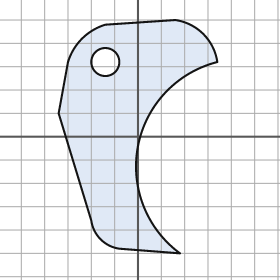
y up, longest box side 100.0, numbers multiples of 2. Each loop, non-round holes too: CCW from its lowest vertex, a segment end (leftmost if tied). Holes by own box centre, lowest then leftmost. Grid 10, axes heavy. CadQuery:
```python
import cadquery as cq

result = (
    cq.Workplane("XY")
    .moveTo(18.0, -50.0)
    .threePointArc((0.0, -4.0), (34.0, 32.0))
    .threePointArc((28.0, 44.0), (16.0, 50.0))
    .lineTo(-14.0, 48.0)
    .threePointArc((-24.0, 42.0), (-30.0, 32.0))
    .lineTo(-34.0, 10.0)
    .lineTo(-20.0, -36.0)
    .threePointArc((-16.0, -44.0), (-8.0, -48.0))
    .close()
    .moveTo(-14.0, 32.0)
    .circle(6.0)
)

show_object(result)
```